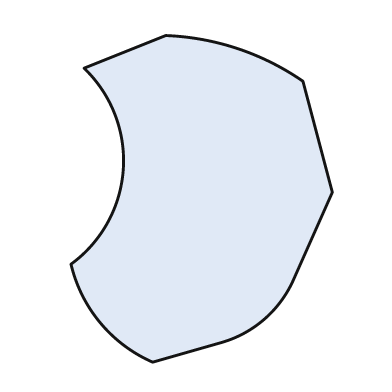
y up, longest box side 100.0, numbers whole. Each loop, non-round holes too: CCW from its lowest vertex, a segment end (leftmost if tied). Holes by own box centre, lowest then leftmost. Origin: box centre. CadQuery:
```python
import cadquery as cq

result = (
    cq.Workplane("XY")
    .moveTo(-15.0, -50.0)
    .lineTo(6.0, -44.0)
    .threePointArc((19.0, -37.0), (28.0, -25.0))
    .lineTo(40.0, 2.0)
    .lineTo(31.0, 36.0)
    .threePointArc((11.0, 46.0), (-11.0, 50.0))
    .lineTo(-36.0, 40.0)
    .threePointArc((-24.0, 9.0), (-40.0, -20.0))
    .threePointArc((-31.0, -38.0), (-15.0, -50.0))
    .close()
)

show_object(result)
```